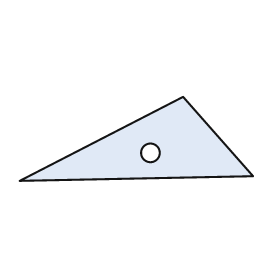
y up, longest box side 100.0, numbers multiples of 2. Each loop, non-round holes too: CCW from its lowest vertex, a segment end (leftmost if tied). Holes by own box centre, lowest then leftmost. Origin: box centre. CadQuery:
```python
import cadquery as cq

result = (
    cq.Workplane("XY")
    .moveTo(-50.0, -18.0)
    .lineTo(50.0, -16.0)
    .lineTo(20.0, 18.0)
    .close()
    .moveTo(6.0, -6.0)
    .circle(4.0)
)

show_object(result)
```